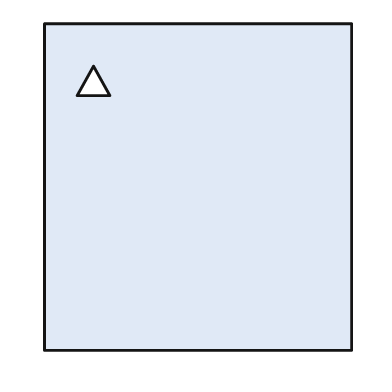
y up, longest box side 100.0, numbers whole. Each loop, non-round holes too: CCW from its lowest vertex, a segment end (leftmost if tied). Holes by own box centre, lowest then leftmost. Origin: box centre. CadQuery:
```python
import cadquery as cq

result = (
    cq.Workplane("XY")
    .moveTo(-47.0, -50.0)
    .lineTo(47.0, -50.0)
    .lineTo(47.0, 50.0)
    .lineTo(-47.0, 50.0)
    .close()
    .moveTo(-37.0, 28.0)
    .lineTo(-27.0, 28.0)
    .lineTo(-32.0, 37.0)
    .close()
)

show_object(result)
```